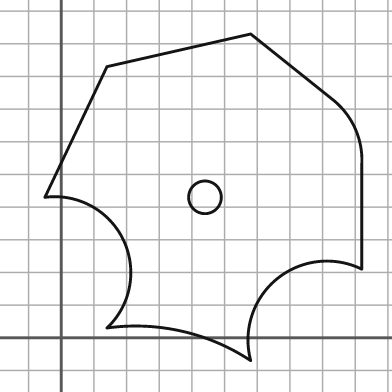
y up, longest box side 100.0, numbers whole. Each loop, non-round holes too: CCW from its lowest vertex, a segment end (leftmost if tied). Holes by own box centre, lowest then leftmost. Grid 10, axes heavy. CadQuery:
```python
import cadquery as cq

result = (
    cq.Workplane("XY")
    .moveTo(58.0, -7.0)
    .threePointArc((66.0, 18.0), (92.0, 21.0))
    .lineTo(92.0, 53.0)
    .threePointArc((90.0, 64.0), (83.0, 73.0))
    .lineTo(58.0, 93.0)
    .lineTo(14.0, 83.0)
    .lineTo(-5.0, 43.0)
    .threePointArc((19.0, 30.0), (14.0, 3.0))
    .threePointArc((37.0, 2.0), (58.0, -7.0))
    .close()
    .moveTo(44.0, 43.0)
    .circle(5.0)
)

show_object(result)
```